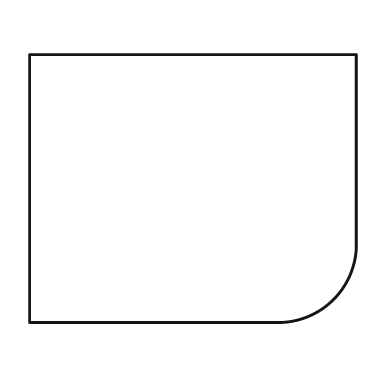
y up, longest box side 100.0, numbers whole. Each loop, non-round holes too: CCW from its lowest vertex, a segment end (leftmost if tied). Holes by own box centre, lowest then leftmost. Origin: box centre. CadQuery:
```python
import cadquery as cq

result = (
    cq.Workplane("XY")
    .moveTo(-50.0, -41.0)
    .lineTo(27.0, -41.0)
    .threePointArc((43.0, -34.0), (50.0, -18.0))
    .lineTo(50.0, 41.0)
    .lineTo(-50.0, 41.0)
    .close()
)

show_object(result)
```